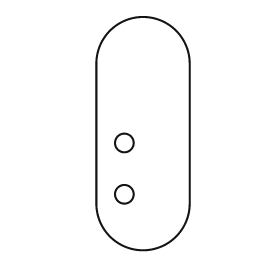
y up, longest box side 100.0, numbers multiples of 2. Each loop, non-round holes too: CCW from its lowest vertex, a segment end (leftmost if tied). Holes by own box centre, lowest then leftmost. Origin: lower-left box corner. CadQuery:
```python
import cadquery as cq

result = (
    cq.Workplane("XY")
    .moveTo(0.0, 20.0)
    .threePointArc((20.0, 0.0), (40.0, 20.0))
    .lineTo(40.0, 80.0)
    .threePointArc((20.0, 100.0), (0.0, 80.0))
    .close()
    .moveTo(12.0, 24.0)
    .circle(4.0)
    .moveTo(12.0, 46.0)
    .circle(4.0)
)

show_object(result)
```